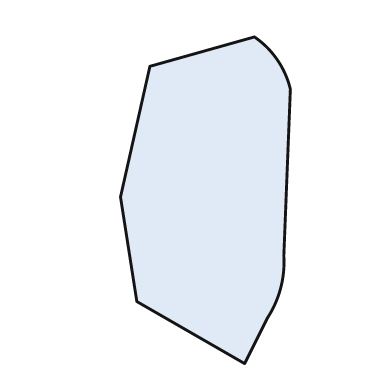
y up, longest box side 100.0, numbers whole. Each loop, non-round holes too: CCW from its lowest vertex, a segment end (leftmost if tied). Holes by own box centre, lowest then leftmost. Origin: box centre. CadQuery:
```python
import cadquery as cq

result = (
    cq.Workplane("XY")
    .moveTo(12.0, -50.0)
    .lineTo(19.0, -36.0)
    .threePointArc((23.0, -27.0), (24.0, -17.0))
    .lineTo(26.0, 34.0)
    .threePointArc((22.0, 43.0), (15.0, 50.0))
    .lineTo(-17.0, 41.0)
    .lineTo(-26.0, 1.0)
    .lineTo(-21.0, -31.0)
    .close()
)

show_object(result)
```